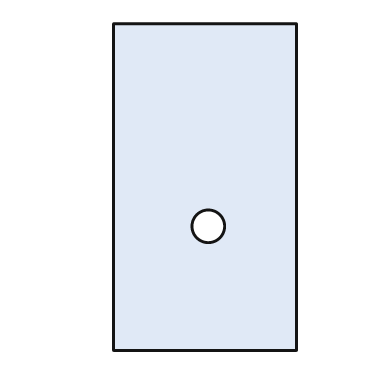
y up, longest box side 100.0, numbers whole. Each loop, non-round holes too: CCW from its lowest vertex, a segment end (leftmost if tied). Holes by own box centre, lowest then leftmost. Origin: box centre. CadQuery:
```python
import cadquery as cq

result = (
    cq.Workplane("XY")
    .moveTo(-28.0, -50.0)
    .lineTo(28.0, -50.0)
    .lineTo(28.0, 50.0)
    .lineTo(-28.0, 50.0)
    .close()
    .moveTo(1.0, -12.0)
    .circle(5.0)
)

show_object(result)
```